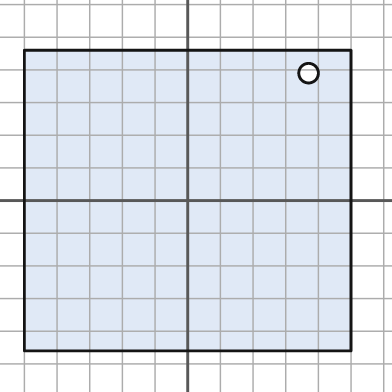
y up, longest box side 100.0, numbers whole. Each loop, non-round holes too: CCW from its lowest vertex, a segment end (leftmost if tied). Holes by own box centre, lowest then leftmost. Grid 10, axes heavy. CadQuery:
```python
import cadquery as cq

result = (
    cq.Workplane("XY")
    .moveTo(-50.0, -46.0)
    .lineTo(50.0, -46.0)
    .lineTo(50.0, 46.0)
    .lineTo(-50.0, 46.0)
    .close()
    .moveTo(37.0, 39.0)
    .circle(3.0)
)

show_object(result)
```